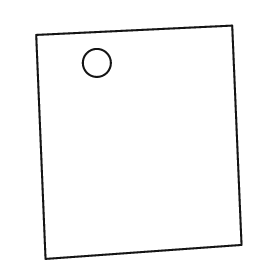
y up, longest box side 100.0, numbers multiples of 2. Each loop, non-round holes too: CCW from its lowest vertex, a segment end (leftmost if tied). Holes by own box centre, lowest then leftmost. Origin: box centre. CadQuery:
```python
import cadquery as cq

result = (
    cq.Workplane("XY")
    .moveTo(-40.0, -50.0)
    .lineTo(44.0, -44.0)
    .lineTo(40.0, 50.0)
    .lineTo(-44.0, 46.0)
    .close()
    .moveTo(-18.0, 34.0)
    .circle(6.0)
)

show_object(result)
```